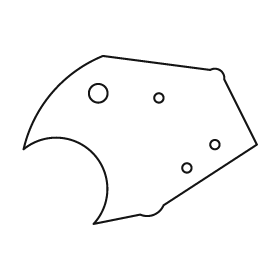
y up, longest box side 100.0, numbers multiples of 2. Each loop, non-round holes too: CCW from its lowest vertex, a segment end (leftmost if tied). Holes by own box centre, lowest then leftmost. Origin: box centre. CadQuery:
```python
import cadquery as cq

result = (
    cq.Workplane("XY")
    .moveTo(-20.0, -36.0)
    .lineTo(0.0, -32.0)
    .threePointArc((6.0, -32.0), (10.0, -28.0))
    .lineTo(50.0, -2.0)
    .lineTo(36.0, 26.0)
    .threePointArc((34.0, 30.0), (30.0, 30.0))
    .lineTo(-16.0, 36.0)
    .threePointArc((-38.0, 20.0), (-50.0, -4.0))
    .threePointArc((-20.0, -6.0), (-20.0, -36.0))
    .close()
    .moveTo(20.0, -12.0)
    .circle(2.0)
    .moveTo(32.0, -2.0)
    .circle(2.0)
    .moveTo(8.0, 18.0)
    .circle(2.0)
    .moveTo(-18.0, 20.0)
    .circle(4.0)
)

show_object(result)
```